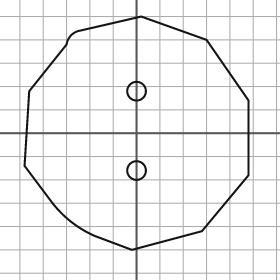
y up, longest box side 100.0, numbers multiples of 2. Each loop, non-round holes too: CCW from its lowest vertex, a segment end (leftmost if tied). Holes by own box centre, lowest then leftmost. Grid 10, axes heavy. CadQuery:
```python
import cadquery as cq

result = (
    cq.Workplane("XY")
    .moveTo(-2.0, -50.0)
    .lineTo(28.0, -42.0)
    .lineTo(48.0, -18.0)
    .lineTo(48.0, 14.0)
    .lineTo(30.0, 40.0)
    .lineTo(2.0, 50.0)
    .lineTo(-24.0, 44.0)
    .threePointArc((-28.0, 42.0), (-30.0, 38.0))
    .lineTo(-46.0, 18.0)
    .lineTo(-48.0, -14.0)
    .lineTo(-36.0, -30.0)
    .threePointArc((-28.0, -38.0), (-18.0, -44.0))
    .close()
    .moveTo(0.0, -16.0)
    .circle(4.0)
    .moveTo(0.0, 18.0)
    .circle(4.0)
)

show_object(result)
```